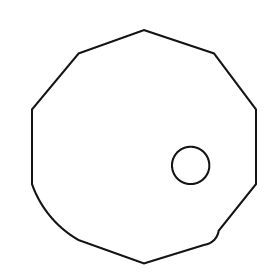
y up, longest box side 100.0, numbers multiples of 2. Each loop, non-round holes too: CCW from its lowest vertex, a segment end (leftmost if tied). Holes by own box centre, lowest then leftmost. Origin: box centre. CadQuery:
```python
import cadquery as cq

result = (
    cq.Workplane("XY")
    .moveTo(0.0, -50.0)
    .lineTo(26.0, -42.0)
    .threePointArc((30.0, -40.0), (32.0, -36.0))
    .lineTo(48.0, -16.0)
    .lineTo(48.0, 16.0)
    .lineTo(30.0, 40.0)
    .lineTo(0.0, 50.0)
    .lineTo(-28.0, 40.0)
    .lineTo(-48.0, 16.0)
    .lineTo(-48.0, -16.0)
    .threePointArc((-40.0, -30.0), (-28.0, -40.0))
    .close()
    .moveTo(20.0, -8.0)
    .circle(8.0)
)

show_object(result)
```